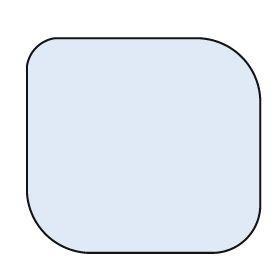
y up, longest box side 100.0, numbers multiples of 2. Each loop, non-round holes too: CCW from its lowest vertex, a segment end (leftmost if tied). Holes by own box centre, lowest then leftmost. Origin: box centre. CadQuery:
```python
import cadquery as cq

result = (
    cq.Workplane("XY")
    .moveTo(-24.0, -46.0)
    .lineTo(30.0, -46.0)
    .threePointArc((44.0, -40.0), (50.0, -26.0))
    .lineTo(50.0, 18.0)
    .threePointArc((42.0, 38.0), (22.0, 46.0))
    .lineTo(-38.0, 46.0)
    .threePointArc((-46.0, 42.0), (-50.0, 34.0))
    .lineTo(-50.0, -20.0)
    .threePointArc((-42.0, -38.0), (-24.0, -46.0))
    .close()
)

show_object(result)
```